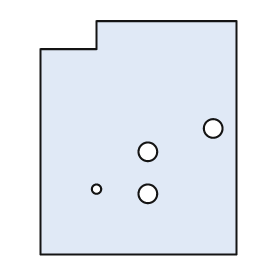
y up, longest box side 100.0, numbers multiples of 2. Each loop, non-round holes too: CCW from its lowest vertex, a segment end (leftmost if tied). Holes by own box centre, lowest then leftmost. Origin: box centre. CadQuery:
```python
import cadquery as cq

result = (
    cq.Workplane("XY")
    .moveTo(-42.0, -50.0)
    .lineTo(42.0, -50.0)
    .lineTo(42.0, 50.0)
    .lineTo(-18.0, 50.0)
    .lineTo(-18.0, 38.0)
    .lineTo(-42.0, 38.0)
    .close()
    .moveTo(4.0, -24.0)
    .circle(4.0)
    .moveTo(-18.0, -22.0)
    .circle(2.0)
    .moveTo(4.0, -6.0)
    .circle(4.0)
    .moveTo(32.0, 4.0)
    .circle(4.0)
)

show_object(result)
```